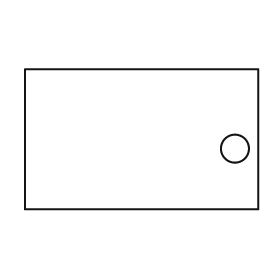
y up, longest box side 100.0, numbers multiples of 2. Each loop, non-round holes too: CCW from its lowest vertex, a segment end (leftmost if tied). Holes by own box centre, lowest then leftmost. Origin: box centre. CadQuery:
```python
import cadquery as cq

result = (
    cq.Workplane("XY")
    .moveTo(-50.0, -30.0)
    .lineTo(50.0, -30.0)
    .lineTo(50.0, 30.0)
    .lineTo(-50.0, 30.0)
    .close()
    .moveTo(40.0, -4.0)
    .circle(6.0)
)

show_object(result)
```